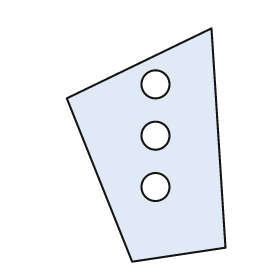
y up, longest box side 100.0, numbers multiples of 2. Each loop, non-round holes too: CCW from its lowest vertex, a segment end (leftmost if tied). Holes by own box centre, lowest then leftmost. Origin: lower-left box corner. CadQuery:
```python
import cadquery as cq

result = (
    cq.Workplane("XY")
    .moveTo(28.0, 0.0)
    .lineTo(68.0, 6.0)
    .lineTo(62.0, 100.0)
    .lineTo(0.0, 70.0)
    .close()
    .moveTo(38.0, 32.0)
    .circle(6.0)
    .moveTo(38.0, 54.0)
    .circle(6.0)
    .moveTo(38.0, 76.0)
    .circle(6.0)
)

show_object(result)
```